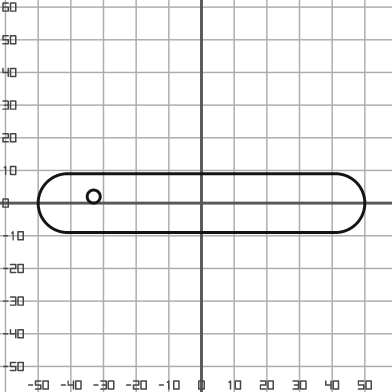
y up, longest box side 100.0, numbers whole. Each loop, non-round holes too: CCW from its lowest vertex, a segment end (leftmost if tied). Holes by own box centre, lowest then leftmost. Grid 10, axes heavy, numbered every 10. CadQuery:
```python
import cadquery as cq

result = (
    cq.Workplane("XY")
    .moveTo(-41.0, -9.0)
    .lineTo(41.0, -9.0)
    .threePointArc((50.0, 0.0), (41.0, 9.0))
    .lineTo(-41.0, 9.0)
    .threePointArc((-50.0, 0.0), (-41.0, -9.0))
    .close()
    .moveTo(-33.0, 2.0)
    .circle(2.0)
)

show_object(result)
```